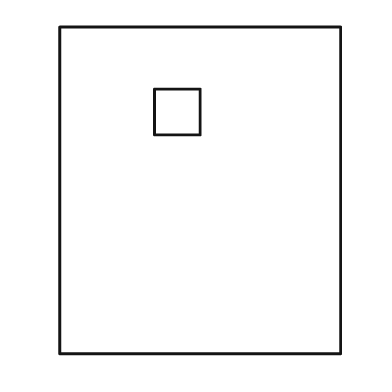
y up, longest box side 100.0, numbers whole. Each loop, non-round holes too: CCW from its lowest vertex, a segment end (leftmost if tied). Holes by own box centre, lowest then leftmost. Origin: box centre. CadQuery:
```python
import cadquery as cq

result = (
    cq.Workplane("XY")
    .moveTo(-43.0, -50.0)
    .lineTo(43.0, -50.0)
    .lineTo(43.0, 50.0)
    .lineTo(-43.0, 50.0)
    .close()
    .moveTo(-14.0, 17.0)
    .lineTo(0.0, 17.0)
    .lineTo(0.0, 31.0)
    .lineTo(-14.0, 31.0)
    .close()
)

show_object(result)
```